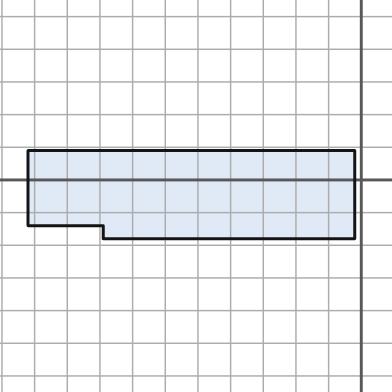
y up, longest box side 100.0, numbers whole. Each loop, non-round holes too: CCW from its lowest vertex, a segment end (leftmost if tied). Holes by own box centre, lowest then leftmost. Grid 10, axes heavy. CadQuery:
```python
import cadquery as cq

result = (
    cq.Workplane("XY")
    .moveTo(-79.0, -18.0)
    .lineTo(-2.0, -18.0)
    .lineTo(-2.0, 9.0)
    .lineTo(-102.0, 9.0)
    .lineTo(-102.0, -14.0)
    .lineTo(-79.0, -14.0)
    .close()
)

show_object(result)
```